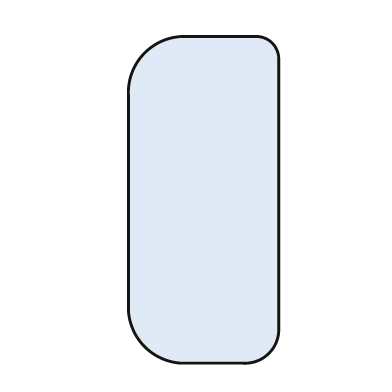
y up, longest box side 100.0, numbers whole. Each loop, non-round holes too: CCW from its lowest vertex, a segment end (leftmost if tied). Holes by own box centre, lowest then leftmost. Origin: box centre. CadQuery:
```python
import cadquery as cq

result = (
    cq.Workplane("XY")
    .moveTo(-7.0, -50.0)
    .lineTo(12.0, -50.0)
    .threePointArc((20.0, -47.0), (23.0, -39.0))
    .lineTo(23.0, 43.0)
    .threePointArc((21.0, 48.0), (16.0, 50.0))
    .lineTo(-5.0, 50.0)
    .threePointArc((-18.0, 45.0), (-23.0, 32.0))
    .lineTo(-23.0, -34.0)
    .threePointArc((-18.0, -45.0), (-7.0, -50.0))
    .close()
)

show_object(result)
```